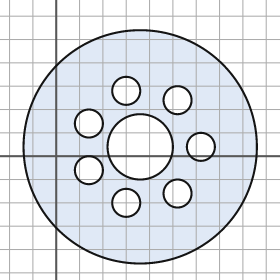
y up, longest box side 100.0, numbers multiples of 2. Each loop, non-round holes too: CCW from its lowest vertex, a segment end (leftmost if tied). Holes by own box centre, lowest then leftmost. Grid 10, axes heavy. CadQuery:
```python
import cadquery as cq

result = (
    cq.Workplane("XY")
    .moveTo(36.0, 4.0)
    .circle(50.0)
    .moveTo(30.0, -20.0)
    .circle(6.0)
    .moveTo(52.0, -16.0)
    .circle(6.0)
    .moveTo(14.0, -6.0)
    .circle(6.0)
    .moveTo(36.0, 4.0)
    .circle(14.0)
    .moveTo(62.0, 4.0)
    .circle(6.0)
    .moveTo(14.0, 14.0)
    .circle(6.0)
    .moveTo(52.0, 24.0)
    .circle(6.0)
    .moveTo(30.0, 28.0)
    .circle(6.0)
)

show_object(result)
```